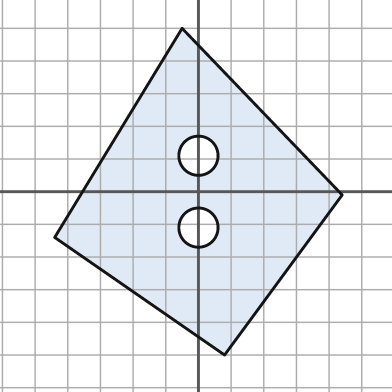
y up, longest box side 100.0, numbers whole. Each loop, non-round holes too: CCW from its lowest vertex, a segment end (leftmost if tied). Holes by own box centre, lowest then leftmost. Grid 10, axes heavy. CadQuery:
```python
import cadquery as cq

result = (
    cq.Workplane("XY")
    .moveTo(8.0, -50.0)
    .lineTo(44.0, -1.0)
    .lineTo(-5.0, 50.0)
    .lineTo(-44.0, -14.0)
    .close()
    .moveTo(0.0, -11.0)
    .circle(6.0)
    .moveTo(0.0, 11.0)
    .circle(6.0)
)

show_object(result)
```